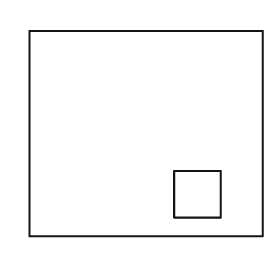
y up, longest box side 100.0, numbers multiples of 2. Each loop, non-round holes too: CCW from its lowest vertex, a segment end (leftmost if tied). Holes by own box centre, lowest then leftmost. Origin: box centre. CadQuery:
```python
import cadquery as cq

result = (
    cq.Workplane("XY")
    .moveTo(-50.0, -44.0)
    .lineTo(50.0, -44.0)
    .lineTo(50.0, 44.0)
    .lineTo(-50.0, 44.0)
    .close()
    .moveTo(12.0, -36.0)
    .lineTo(32.0, -36.0)
    .lineTo(32.0, -16.0)
    .lineTo(12.0, -16.0)
    .close()
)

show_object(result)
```